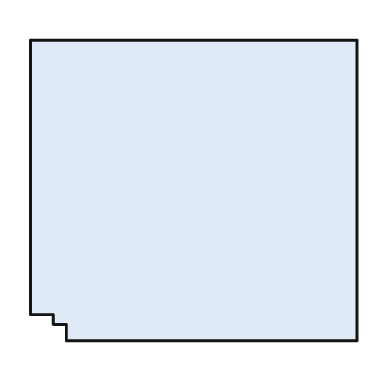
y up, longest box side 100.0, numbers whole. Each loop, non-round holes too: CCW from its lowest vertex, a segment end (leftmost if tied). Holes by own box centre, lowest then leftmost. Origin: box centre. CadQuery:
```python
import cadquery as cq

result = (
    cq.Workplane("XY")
    .moveTo(-39.0, -46.0)
    .lineTo(50.0, -46.0)
    .lineTo(50.0, 46.0)
    .lineTo(-50.0, 46.0)
    .lineTo(-50.0, -38.0)
    .lineTo(-43.0, -38.0)
    .lineTo(-43.0, -41.0)
    .lineTo(-39.0, -41.0)
    .close()
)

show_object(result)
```